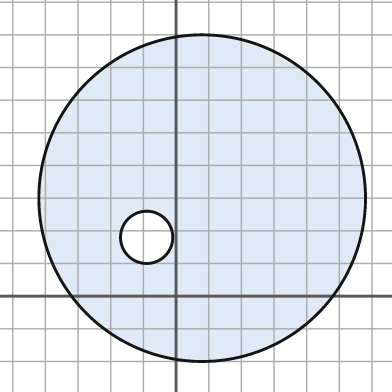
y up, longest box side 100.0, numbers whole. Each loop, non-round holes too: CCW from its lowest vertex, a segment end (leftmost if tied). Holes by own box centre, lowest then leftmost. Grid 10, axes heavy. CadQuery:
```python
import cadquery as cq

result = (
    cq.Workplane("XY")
    .moveTo(8.0, 30.0)
    .circle(50.0)
    .moveTo(-9.0, 18.0)
    .circle(8.0)
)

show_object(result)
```